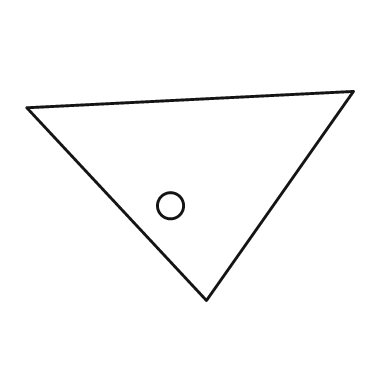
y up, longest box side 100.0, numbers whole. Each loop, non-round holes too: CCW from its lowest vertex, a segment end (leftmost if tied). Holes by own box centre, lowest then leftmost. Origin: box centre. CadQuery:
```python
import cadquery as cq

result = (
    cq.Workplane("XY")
    .moveTo(5.0, -32.0)
    .lineTo(50.0, 32.0)
    .lineTo(-50.0, 27.0)
    .close()
    .moveTo(-6.0, -3.0)
    .circle(4.0)
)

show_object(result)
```